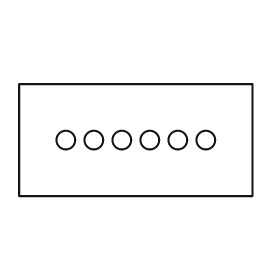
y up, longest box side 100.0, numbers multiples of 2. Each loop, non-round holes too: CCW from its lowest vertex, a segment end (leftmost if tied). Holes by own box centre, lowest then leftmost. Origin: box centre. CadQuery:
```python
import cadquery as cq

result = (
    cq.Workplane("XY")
    .moveTo(-50.0, -24.0)
    .lineTo(50.0, -24.0)
    .lineTo(50.0, 24.0)
    .lineTo(-50.0, 24.0)
    .close()
    .moveTo(-30.0, 0.0)
    .circle(4.0)
    .moveTo(-18.0, 0.0)
    .circle(4.0)
    .moveTo(-6.0, 0.0)
    .circle(4.0)
    .moveTo(6.0, 0.0)
    .circle(4.0)
    .moveTo(18.0, 0.0)
    .circle(4.0)
    .moveTo(30.0, 0.0)
    .circle(4.0)
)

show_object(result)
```